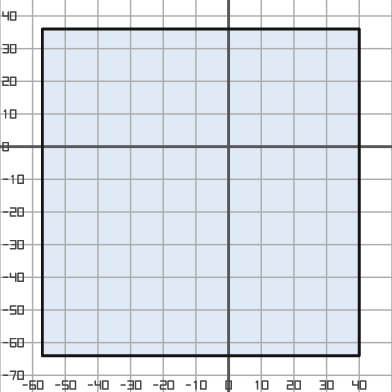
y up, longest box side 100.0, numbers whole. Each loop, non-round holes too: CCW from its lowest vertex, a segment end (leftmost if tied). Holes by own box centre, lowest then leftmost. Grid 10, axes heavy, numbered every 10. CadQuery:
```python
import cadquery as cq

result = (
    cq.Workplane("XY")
    .moveTo(-57.0, -64.0)
    .lineTo(40.0, -64.0)
    .lineTo(40.0, 36.0)
    .lineTo(-57.0, 36.0)
    .close()
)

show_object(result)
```